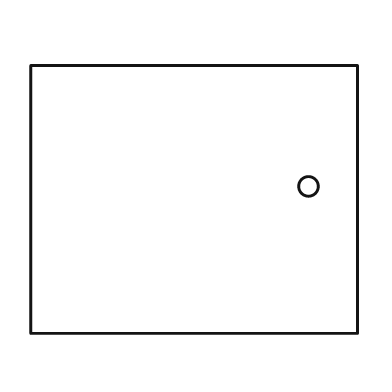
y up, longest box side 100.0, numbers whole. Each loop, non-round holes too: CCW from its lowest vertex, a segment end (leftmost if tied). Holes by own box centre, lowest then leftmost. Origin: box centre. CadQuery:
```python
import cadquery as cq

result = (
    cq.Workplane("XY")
    .moveTo(-50.0, -41.0)
    .lineTo(50.0, -41.0)
    .lineTo(50.0, 41.0)
    .lineTo(-50.0, 41.0)
    .close()
    .moveTo(35.0, 4.0)
    .circle(3.0)
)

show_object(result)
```